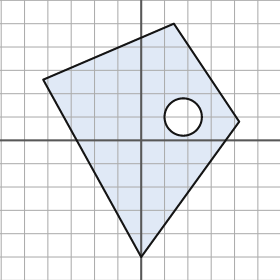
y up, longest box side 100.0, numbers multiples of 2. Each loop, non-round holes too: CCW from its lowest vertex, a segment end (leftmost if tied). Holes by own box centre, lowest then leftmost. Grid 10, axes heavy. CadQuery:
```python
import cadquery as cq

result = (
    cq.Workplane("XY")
    .moveTo(0.0, -50.0)
    .lineTo(42.0, 8.0)
    .lineTo(14.0, 50.0)
    .lineTo(-42.0, 26.0)
    .close()
    .moveTo(18.0, 10.0)
    .circle(8.0)
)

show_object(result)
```